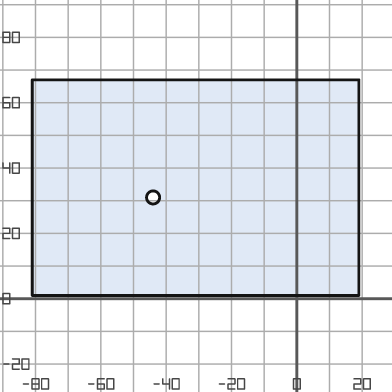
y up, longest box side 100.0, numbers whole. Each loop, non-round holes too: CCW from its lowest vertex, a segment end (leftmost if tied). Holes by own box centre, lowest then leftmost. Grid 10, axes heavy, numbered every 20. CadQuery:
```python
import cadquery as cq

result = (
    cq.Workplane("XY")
    .moveTo(-81.0, 1.0)
    .lineTo(19.0, 1.0)
    .lineTo(19.0, 67.0)
    .lineTo(-81.0, 67.0)
    .close()
    .moveTo(-44.0, 31.0)
    .circle(2.0)
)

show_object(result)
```